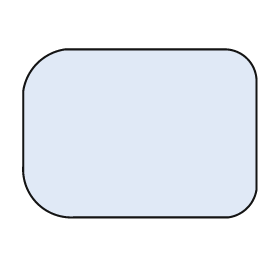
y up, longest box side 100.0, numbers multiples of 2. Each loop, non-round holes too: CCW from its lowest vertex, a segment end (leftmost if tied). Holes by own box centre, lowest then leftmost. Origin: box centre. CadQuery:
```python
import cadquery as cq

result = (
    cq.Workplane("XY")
    .moveTo(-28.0, -36.0)
    .lineTo(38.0, -36.0)
    .threePointArc((46.0, -32.0), (50.0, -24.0))
    .lineTo(50.0, 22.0)
    .threePointArc((46.0, 32.0), (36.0, 36.0))
    .lineTo(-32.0, 36.0)
    .threePointArc((-44.0, 30.0), (-50.0, 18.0))
    .lineTo(-50.0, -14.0)
    .threePointArc((-44.0, -30.0), (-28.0, -36.0))
    .close()
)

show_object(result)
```